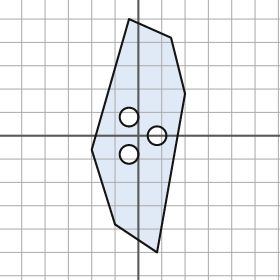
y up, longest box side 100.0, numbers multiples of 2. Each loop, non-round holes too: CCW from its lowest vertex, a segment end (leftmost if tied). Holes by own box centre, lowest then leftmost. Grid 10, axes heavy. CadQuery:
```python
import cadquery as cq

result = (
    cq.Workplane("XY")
    .moveTo(8.0, -50.0)
    .lineTo(20.0, 18.0)
    .lineTo(14.0, 42.0)
    .lineTo(-4.0, 50.0)
    .lineTo(-20.0, -6.0)
    .lineTo(-10.0, -38.0)
    .close()
    .moveTo(-4.0, -8.0)
    .circle(4.0)
    .moveTo(8.0, 0.0)
    .circle(4.0)
    .moveTo(-4.0, 8.0)
    .circle(4.0)
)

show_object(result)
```